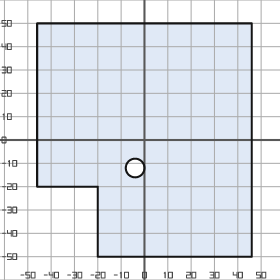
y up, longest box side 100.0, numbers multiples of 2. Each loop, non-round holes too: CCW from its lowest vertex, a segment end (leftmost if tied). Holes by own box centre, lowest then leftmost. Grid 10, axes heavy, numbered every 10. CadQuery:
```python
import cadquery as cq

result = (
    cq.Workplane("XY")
    .moveTo(-20.0, -50.0)
    .lineTo(46.0, -50.0)
    .lineTo(46.0, 50.0)
    .lineTo(-46.0, 50.0)
    .lineTo(-46.0, -20.0)
    .lineTo(-20.0, -20.0)
    .close()
    .moveTo(-4.0, -12.0)
    .circle(4.0)
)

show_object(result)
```